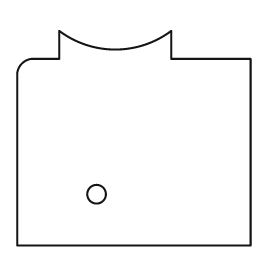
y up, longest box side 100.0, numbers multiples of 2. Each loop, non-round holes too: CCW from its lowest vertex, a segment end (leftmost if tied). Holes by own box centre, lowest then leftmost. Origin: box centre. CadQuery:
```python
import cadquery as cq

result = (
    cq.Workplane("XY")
    .moveTo(-50.0, -46.0)
    .lineTo(50.0, -46.0)
    .lineTo(50.0, 34.0)
    .lineTo(16.0, 34.0)
    .lineTo(16.0, 46.0)
    .threePointArc((-8.0, 38.0), (-32.0, 46.0))
    .lineTo(-32.0, 34.0)
    .lineTo(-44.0, 34.0)
    .threePointArc((-48.0, 32.0), (-50.0, 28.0))
    .close()
    .moveTo(-16.0, -24.0)
    .circle(4.0)
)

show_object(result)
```